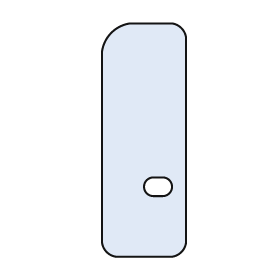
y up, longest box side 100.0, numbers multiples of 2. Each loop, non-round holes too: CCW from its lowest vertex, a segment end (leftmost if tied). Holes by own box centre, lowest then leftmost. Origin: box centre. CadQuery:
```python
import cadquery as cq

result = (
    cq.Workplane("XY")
    .moveTo(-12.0, -50.0)
    .lineTo(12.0, -50.0)
    .threePointArc((16.0, -48.0), (18.0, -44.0))
    .lineTo(18.0, 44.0)
    .threePointArc((16.0, 48.0), (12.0, 50.0))
    .lineTo(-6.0, 50.0)
    .threePointArc((-14.0, 46.0), (-18.0, 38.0))
    .lineTo(-18.0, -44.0)
    .threePointArc((-16.0, -48.0), (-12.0, -50.0))
    .close()
    .moveTo(4.0, -24.0)
    .lineTo(8.0, -24.0)
    .threePointArc((12.0, -20.0), (8.0, -16.0))
    .lineTo(4.0, -16.0)
    .threePointArc((0.0, -20.0), (4.0, -24.0))
    .close()
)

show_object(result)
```